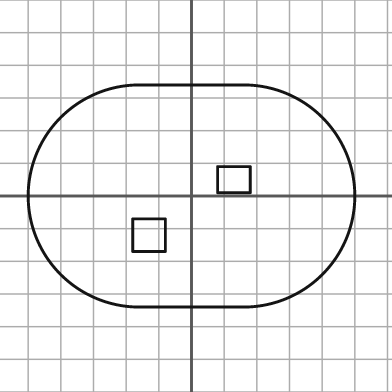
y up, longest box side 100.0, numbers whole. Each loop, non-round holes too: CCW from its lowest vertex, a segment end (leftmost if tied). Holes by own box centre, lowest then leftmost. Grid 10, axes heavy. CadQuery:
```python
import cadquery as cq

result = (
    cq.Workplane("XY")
    .moveTo(-16.0, -34.0)
    .lineTo(16.0, -34.0)
    .threePointArc((50.0, 0.0), (16.0, 34.0))
    .lineTo(-16.0, 34.0)
    .threePointArc((-50.0, 0.0), (-16.0, -34.0))
    .close()
    .moveTo(-18.0, -17.0)
    .lineTo(-8.0, -17.0)
    .lineTo(-8.0, -7.0)
    .lineTo(-18.0, -7.0)
    .close()
    .moveTo(8.0, 1.0)
    .lineTo(18.0, 1.0)
    .lineTo(18.0, 9.0)
    .lineTo(8.0, 9.0)
    .close()
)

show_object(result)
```